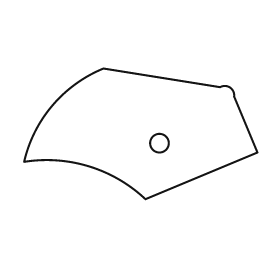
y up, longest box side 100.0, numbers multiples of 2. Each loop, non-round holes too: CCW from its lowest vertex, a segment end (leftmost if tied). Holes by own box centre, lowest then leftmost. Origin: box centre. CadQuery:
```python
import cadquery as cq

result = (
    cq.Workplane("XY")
    .moveTo(2.0, -28.0)
    .lineTo(50.0, -8.0)
    .lineTo(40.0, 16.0)
    .threePointArc((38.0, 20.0), (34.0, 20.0))
    .lineTo(-16.0, 28.0)
    .threePointArc((-38.0, 12.0), (-50.0, -12.0))
    .threePointArc((-22.0, -14.0), (2.0, -28.0))
    .close()
    .moveTo(8.0, -4.0)
    .circle(4.0)
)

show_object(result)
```